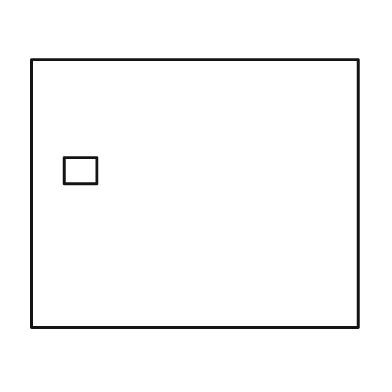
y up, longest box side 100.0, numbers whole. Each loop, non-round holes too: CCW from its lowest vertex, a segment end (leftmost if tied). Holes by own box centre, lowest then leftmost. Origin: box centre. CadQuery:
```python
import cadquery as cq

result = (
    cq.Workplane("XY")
    .moveTo(-50.0, -41.0)
    .lineTo(50.0, -41.0)
    .lineTo(50.0, 41.0)
    .lineTo(-50.0, 41.0)
    .close()
    .moveTo(-40.0, 3.0)
    .lineTo(-30.0, 3.0)
    .lineTo(-30.0, 11.0)
    .lineTo(-40.0, 11.0)
    .close()
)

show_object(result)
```